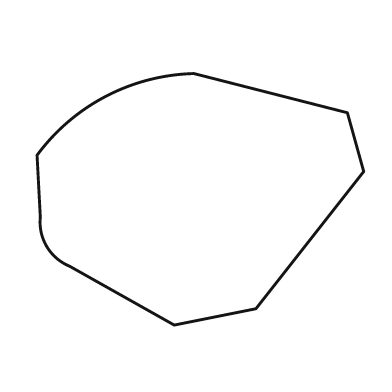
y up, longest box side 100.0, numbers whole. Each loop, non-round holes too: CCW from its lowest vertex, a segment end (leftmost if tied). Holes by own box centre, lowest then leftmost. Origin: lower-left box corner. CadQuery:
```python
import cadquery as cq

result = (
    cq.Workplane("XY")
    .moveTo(42.0, 0.0)
    .lineTo(67.0, 5.0)
    .lineTo(100.0, 47.0)
    .lineTo(95.0, 65.0)
    .lineTo(48.0, 77.0)
    .threePointArc((21.0, 70.0), (0.0, 52.0))
    .lineTo(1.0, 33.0)
    .threePointArc((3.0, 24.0), (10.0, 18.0))
    .close()
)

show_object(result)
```